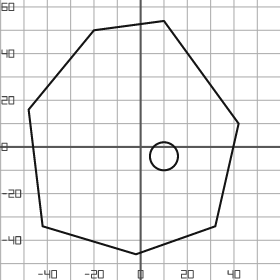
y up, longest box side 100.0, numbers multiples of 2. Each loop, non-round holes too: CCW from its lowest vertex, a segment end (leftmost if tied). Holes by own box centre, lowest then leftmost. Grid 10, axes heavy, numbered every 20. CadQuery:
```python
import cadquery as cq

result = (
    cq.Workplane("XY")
    .moveTo(-2.0, -46.0)
    .lineTo(32.0, -34.0)
    .lineTo(42.0, 10.0)
    .lineTo(10.0, 54.0)
    .lineTo(-20.0, 50.0)
    .lineTo(-48.0, 16.0)
    .lineTo(-42.0, -34.0)
    .close()
    .moveTo(10.0, -4.0)
    .circle(6.0)
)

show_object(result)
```